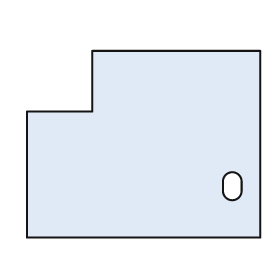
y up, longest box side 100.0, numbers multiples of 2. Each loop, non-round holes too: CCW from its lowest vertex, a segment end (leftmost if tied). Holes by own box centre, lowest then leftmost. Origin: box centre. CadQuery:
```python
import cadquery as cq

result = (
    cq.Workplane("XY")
    .moveTo(-50.0, -40.0)
    .lineTo(50.0, -40.0)
    .lineTo(50.0, 40.0)
    .lineTo(-22.0, 40.0)
    .lineTo(-22.0, 14.0)
    .lineTo(-50.0, 14.0)
    .close()
    .moveTo(34.0, -20.0)
    .threePointArc((38.0, -24.0), (42.0, -20.0))
    .lineTo(42.0, -16.0)
    .threePointArc((38.0, -12.0), (34.0, -16.0))
    .close()
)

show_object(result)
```